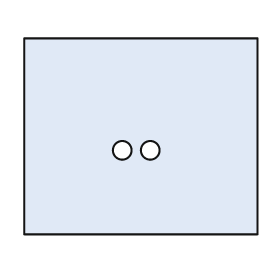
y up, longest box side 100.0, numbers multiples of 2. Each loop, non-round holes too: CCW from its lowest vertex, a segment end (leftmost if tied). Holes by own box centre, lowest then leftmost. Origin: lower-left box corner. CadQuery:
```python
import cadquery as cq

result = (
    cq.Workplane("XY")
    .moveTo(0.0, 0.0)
    .lineTo(100.0, 0.0)
    .lineTo(100.0, 84.0)
    .lineTo(0.0, 84.0)
    .close()
    .moveTo(42.0, 36.0)
    .circle(4.0)
    .moveTo(54.0, 36.0)
    .circle(4.0)
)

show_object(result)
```